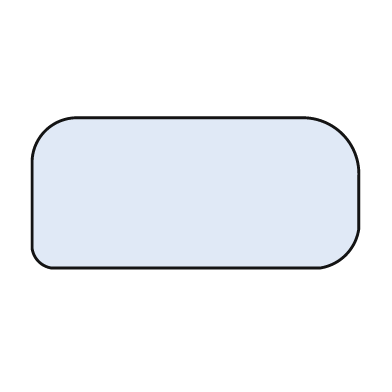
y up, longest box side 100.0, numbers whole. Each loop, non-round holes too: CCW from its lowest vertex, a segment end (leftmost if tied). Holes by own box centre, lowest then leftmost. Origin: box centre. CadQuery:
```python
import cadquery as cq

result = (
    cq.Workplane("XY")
    .moveTo(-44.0, -23.0)
    .lineTo(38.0, -23.0)
    .threePointArc((46.0, -19.0), (50.0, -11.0))
    .lineTo(50.0, 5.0)
    .threePointArc((45.0, 18.0), (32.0, 23.0))
    .lineTo(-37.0, 23.0)
    .threePointArc((-46.0, 19.0), (-50.0, 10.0))
    .lineTo(-50.0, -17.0)
    .threePointArc((-48.0, -21.0), (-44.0, -23.0))
    .close()
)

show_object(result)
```